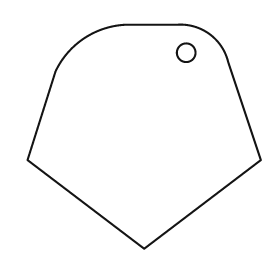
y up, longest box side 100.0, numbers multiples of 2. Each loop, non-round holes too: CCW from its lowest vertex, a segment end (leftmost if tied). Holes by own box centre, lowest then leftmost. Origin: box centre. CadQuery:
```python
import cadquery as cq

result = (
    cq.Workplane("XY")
    .moveTo(0.0, -48.0)
    .lineTo(50.0, -10.0)
    .lineTo(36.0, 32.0)
    .threePointArc((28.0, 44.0), (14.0, 48.0))
    .lineTo(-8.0, 48.0)
    .threePointArc((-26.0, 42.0), (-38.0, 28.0))
    .lineTo(-50.0, -10.0)
    .close()
    .moveTo(18.0, 36.0)
    .circle(4.0)
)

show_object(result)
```